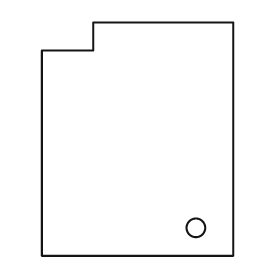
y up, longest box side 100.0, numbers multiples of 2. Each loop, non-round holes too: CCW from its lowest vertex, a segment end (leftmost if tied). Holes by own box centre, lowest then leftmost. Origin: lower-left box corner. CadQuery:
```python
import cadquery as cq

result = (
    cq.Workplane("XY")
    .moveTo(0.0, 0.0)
    .lineTo(82.0, 0.0)
    .lineTo(82.0, 100.0)
    .lineTo(22.0, 100.0)
    .lineTo(22.0, 88.0)
    .lineTo(0.0, 88.0)
    .close()
    .moveTo(66.0, 12.0)
    .circle(4.0)
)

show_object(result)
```